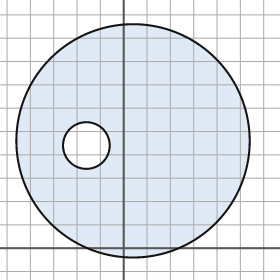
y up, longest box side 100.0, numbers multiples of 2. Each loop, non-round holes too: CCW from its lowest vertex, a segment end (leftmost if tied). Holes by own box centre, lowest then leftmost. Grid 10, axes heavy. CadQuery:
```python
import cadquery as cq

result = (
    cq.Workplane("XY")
    .moveTo(4.0, 46.0)
    .circle(50.0)
    .moveTo(-16.0, 44.0)
    .circle(10.0)
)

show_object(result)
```